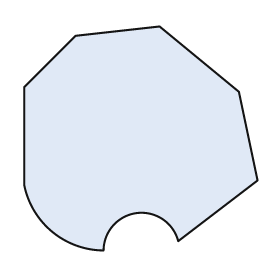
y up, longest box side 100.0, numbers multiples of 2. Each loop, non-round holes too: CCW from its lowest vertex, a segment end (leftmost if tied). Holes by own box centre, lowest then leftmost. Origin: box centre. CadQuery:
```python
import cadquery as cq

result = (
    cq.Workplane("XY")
    .moveTo(-16.0, -48.0)
    .threePointArc((-2.0, -32.0), (16.0, -44.0))
    .lineTo(50.0, -18.0)
    .lineTo(42.0, 20.0)
    .lineTo(8.0, 48.0)
    .lineTo(-28.0, 44.0)
    .lineTo(-50.0, 22.0)
    .lineTo(-50.0, -20.0)
    .threePointArc((-38.0, -40.0), (-16.0, -48.0))
    .close()
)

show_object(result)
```